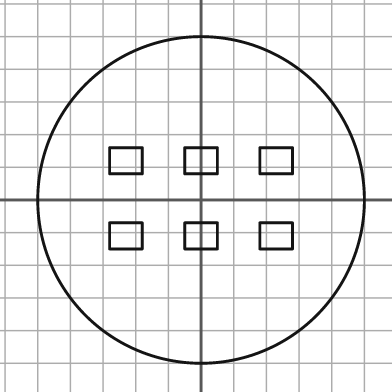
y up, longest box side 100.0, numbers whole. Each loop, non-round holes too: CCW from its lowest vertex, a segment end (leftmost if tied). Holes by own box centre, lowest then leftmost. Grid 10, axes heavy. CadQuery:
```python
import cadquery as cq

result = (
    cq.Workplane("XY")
    .moveTo(0.0, 0.0)
    .circle(50.0)
    .moveTo(-28.0, -15.0)
    .lineTo(-18.0, -15.0)
    .lineTo(-18.0, -7.0)
    .lineTo(-28.0, -7.0)
    .close()
    .moveTo(-5.0, -15.0)
    .lineTo(5.0, -15.0)
    .lineTo(5.0, -7.0)
    .lineTo(-5.0, -7.0)
    .close()
    .moveTo(18.0, -15.0)
    .lineTo(28.0, -15.0)
    .lineTo(28.0, -7.0)
    .lineTo(18.0, -7.0)
    .close()
    .moveTo(-28.0, 8.0)
    .lineTo(-18.0, 8.0)
    .lineTo(-18.0, 16.0)
    .lineTo(-28.0, 16.0)
    .close()
    .moveTo(-5.0, 8.0)
    .lineTo(5.0, 8.0)
    .lineTo(5.0, 16.0)
    .lineTo(-5.0, 16.0)
    .close()
    .moveTo(18.0, 8.0)
    .lineTo(28.0, 8.0)
    .lineTo(28.0, 16.0)
    .lineTo(18.0, 16.0)
    .close()
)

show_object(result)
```